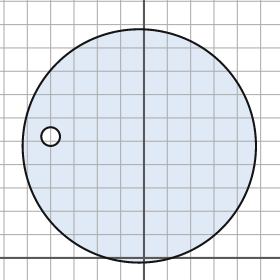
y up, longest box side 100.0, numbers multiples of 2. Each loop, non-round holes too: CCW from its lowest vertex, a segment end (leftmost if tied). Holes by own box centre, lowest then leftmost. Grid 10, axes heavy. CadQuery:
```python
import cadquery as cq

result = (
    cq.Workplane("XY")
    .moveTo(-2.0, 48.0)
    .circle(50.0)
    .moveTo(-40.0, 52.0)
    .circle(4.0)
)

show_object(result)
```